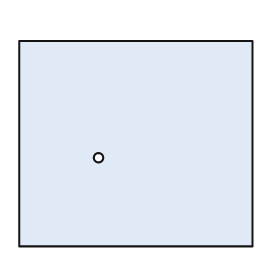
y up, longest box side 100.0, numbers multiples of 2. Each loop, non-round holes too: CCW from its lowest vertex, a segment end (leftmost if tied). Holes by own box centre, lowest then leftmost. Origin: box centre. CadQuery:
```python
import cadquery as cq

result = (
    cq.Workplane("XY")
    .moveTo(-50.0, -44.0)
    .lineTo(50.0, -44.0)
    .lineTo(50.0, 44.0)
    .lineTo(-50.0, 44.0)
    .close()
    .moveTo(-16.0, -6.0)
    .circle(2.0)
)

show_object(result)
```